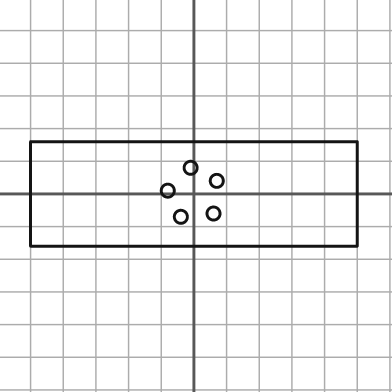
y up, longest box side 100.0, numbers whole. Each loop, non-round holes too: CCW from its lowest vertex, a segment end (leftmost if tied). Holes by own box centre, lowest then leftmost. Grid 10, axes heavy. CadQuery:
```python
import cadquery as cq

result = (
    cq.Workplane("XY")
    .moveTo(-50.0, -16.0)
    .lineTo(50.0, -16.0)
    .lineTo(50.0, 16.0)
    .lineTo(-50.0, 16.0)
    .close()
    .moveTo(-4.0, -7.0)
    .circle(2.0)
    .moveTo(6.0, -6.0)
    .circle(2.0)
    .moveTo(-8.0, 1.0)
    .circle(2.0)
    .moveTo(7.0, 4.0)
    .circle(2.0)
    .moveTo(-1.0, 8.0)
    .circle(2.0)
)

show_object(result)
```